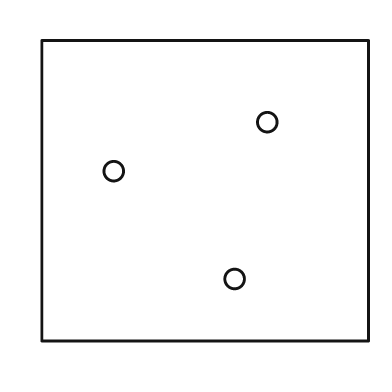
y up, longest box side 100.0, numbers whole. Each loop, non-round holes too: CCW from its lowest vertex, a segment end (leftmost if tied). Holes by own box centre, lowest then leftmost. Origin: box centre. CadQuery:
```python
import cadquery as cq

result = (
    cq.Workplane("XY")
    .moveTo(-50.0, -46.0)
    .lineTo(50.0, -46.0)
    .lineTo(50.0, 46.0)
    .lineTo(-50.0, 46.0)
    .close()
    .moveTo(9.0, -27.0)
    .circle(3.0)
    .moveTo(-28.0, 6.0)
    .circle(3.0)
    .moveTo(19.0, 21.0)
    .circle(3.0)
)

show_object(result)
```